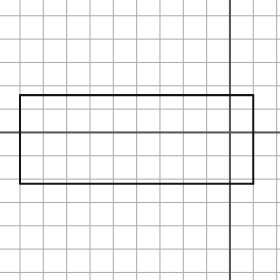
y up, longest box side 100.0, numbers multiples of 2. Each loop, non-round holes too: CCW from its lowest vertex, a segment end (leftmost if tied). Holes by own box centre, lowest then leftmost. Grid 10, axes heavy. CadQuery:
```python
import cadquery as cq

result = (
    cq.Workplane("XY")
    .moveTo(-90.0, -22.0)
    .lineTo(10.0, -22.0)
    .lineTo(10.0, 16.0)
    .lineTo(-90.0, 16.0)
    .close()
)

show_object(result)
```